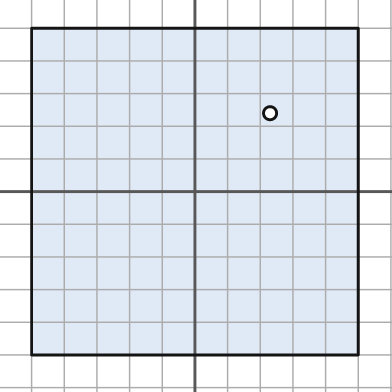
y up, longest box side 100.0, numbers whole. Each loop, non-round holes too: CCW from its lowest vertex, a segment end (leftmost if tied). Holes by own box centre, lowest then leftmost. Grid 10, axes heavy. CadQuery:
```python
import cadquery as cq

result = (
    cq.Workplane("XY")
    .moveTo(-50.0, -50.0)
    .lineTo(50.0, -50.0)
    .lineTo(50.0, 50.0)
    .lineTo(-50.0, 50.0)
    .close()
    .moveTo(23.0, 24.0)
    .circle(2.0)
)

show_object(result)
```